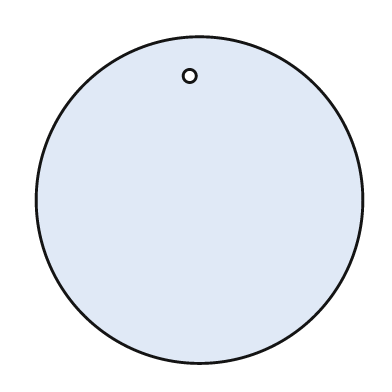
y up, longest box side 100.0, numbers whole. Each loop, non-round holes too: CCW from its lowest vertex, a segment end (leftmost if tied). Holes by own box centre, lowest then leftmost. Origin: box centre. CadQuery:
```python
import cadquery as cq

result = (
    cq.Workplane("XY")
    .moveTo(0.0, 0.0)
    .circle(50.0)
    .moveTo(-3.0, 38.0)
    .circle(2.0)
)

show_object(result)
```